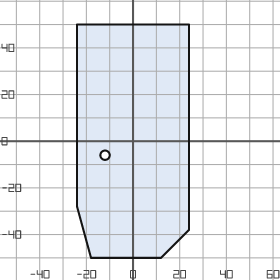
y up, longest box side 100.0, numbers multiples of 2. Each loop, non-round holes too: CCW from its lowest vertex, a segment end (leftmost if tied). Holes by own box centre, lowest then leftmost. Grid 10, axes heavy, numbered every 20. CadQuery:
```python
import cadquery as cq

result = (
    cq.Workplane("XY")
    .moveTo(-18.0, -50.0)
    .lineTo(12.0, -50.0)
    .lineTo(24.0, -38.0)
    .lineTo(24.0, 50.0)
    .lineTo(-24.0, 50.0)
    .lineTo(-24.0, -28.0)
    .close()
    .moveTo(-12.0, -6.0)
    .circle(2.0)
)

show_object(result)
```